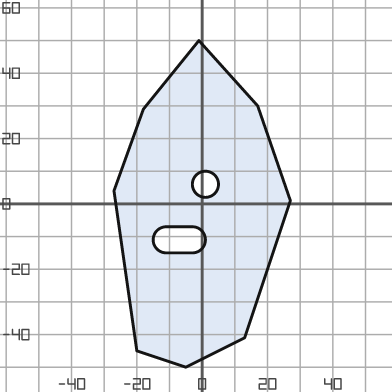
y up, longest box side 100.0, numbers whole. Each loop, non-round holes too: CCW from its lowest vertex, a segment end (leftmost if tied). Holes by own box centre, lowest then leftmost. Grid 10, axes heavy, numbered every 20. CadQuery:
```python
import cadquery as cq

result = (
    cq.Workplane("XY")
    .moveTo(-5.0, -50.0)
    .lineTo(13.0, -41.0)
    .lineTo(27.0, 1.0)
    .lineTo(17.0, 30.0)
    .lineTo(-1.0, 50.0)
    .lineTo(-18.0, 29.0)
    .lineTo(-27.0, 4.0)
    .lineTo(-20.0, -45.0)
    .close()
    .moveTo(-11.0, -15.0)
    .lineTo(-3.0, -15.0)
    .threePointArc((1.0, -11.0), (-3.0, -7.0))
    .lineTo(-11.0, -7.0)
    .threePointArc((-15.0, -11.0), (-11.0, -15.0))
    .close()
    .moveTo(1.0, 6.0)
    .circle(4.0)
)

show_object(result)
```